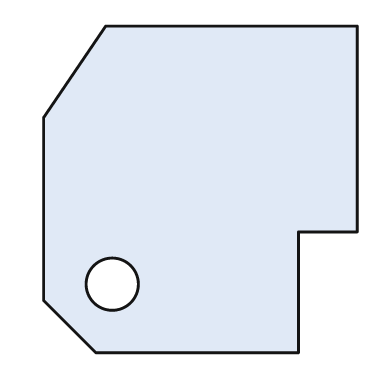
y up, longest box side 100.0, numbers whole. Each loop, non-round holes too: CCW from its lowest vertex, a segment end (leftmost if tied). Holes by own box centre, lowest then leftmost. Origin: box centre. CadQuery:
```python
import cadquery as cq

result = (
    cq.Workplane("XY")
    .moveTo(-32.0, -50.0)
    .lineTo(30.0, -50.0)
    .lineTo(30.0, -13.0)
    .lineTo(48.0, -13.0)
    .lineTo(48.0, 50.0)
    .lineTo(-29.0, 50.0)
    .lineTo(-48.0, 22.0)
    .lineTo(-48.0, -34.0)
    .close()
    .moveTo(-27.0, -29.0)
    .circle(8.0)
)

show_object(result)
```